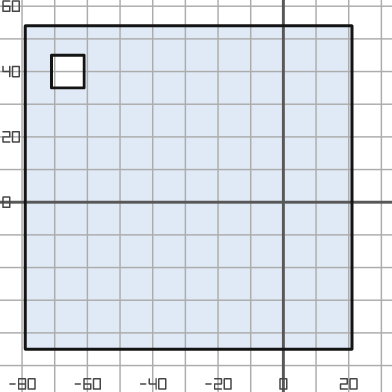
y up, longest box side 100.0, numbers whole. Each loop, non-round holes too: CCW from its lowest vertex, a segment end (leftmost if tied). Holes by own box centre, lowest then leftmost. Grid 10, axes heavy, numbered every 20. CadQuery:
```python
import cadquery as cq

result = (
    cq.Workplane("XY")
    .moveTo(-79.0, -45.0)
    .lineTo(21.0, -45.0)
    .lineTo(21.0, 54.0)
    .lineTo(-79.0, 54.0)
    .close()
    .moveTo(-71.0, 35.0)
    .lineTo(-61.0, 35.0)
    .lineTo(-61.0, 45.0)
    .lineTo(-71.0, 45.0)
    .close()
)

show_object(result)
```